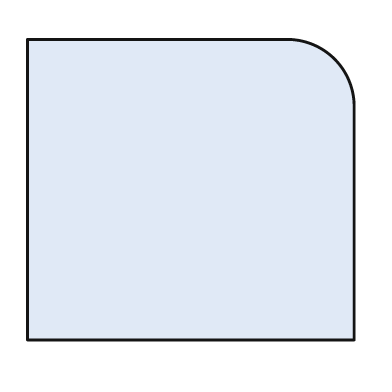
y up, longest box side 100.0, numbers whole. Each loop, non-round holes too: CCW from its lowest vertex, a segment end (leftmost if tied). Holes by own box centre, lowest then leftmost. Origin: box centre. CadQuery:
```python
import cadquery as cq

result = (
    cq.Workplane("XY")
    .moveTo(-50.0, -46.0)
    .lineTo(50.0, -46.0)
    .lineTo(50.0, 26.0)
    .threePointArc((44.0, 40.0), (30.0, 46.0))
    .lineTo(-50.0, 46.0)
    .close()
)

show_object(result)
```